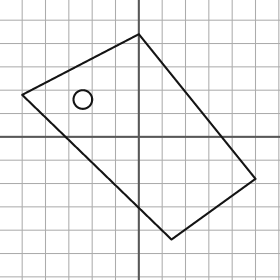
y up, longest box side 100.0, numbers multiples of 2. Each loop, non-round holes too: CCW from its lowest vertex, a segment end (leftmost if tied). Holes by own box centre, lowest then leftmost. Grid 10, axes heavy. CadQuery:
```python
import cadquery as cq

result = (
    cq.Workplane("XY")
    .moveTo(14.0, -44.0)
    .lineTo(50.0, -18.0)
    .lineTo(0.0, 44.0)
    .lineTo(-50.0, 18.0)
    .close()
    .moveTo(-24.0, 16.0)
    .circle(4.0)
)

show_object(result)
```